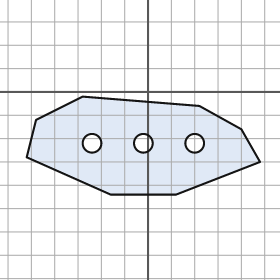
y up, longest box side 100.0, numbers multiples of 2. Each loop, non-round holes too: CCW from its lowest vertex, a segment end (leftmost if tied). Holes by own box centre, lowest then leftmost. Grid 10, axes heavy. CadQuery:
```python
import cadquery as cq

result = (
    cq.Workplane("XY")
    .moveTo(-16.0, -44.0)
    .lineTo(12.0, -44.0)
    .lineTo(48.0, -30.0)
    .lineTo(40.0, -16.0)
    .lineTo(22.0, -6.0)
    .lineTo(-28.0, -2.0)
    .lineTo(-48.0, -12.0)
    .lineTo(-52.0, -28.0)
    .close()
    .moveTo(-24.0, -22.0)
    .circle(4.0)
    .moveTo(-2.0, -22.0)
    .circle(4.0)
    .moveTo(20.0, -22.0)
    .circle(4.0)
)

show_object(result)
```